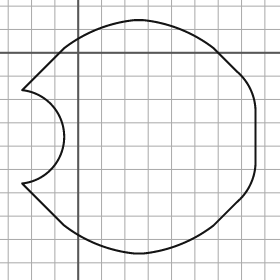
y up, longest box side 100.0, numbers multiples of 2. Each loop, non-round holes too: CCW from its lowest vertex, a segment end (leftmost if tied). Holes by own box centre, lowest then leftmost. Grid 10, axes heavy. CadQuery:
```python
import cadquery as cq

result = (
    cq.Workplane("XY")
    .moveTo(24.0, -86.0)
    .lineTo(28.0, -86.0)
    .threePointArc((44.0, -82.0), (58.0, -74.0))
    .lineTo(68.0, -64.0)
    .threePointArc((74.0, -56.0), (76.0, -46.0))
    .lineTo(76.0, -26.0)
    .threePointArc((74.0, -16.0), (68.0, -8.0))
    .lineTo(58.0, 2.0)
    .threePointArc((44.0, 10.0), (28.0, 14.0))
    .lineTo(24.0, 14.0)
    .threePointArc((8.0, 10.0), (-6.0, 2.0))
    .lineTo(-24.0, -16.0)
    .threePointArc((-6.0, -36.0), (-24.0, -56.0))
    .lineTo(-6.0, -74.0)
    .threePointArc((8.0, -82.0), (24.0, -86.0))
    .close()
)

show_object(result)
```